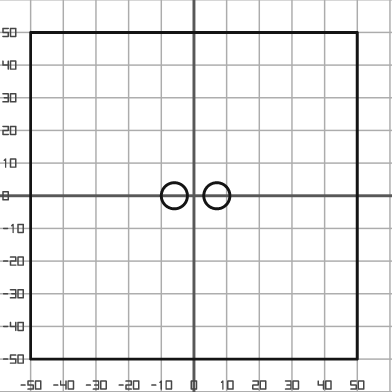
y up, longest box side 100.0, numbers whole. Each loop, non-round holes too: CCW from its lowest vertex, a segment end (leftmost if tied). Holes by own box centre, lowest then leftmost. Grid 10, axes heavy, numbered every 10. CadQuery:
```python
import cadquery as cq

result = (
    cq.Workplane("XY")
    .moveTo(-50.0, -50.0)
    .lineTo(50.0, -50.0)
    .lineTo(50.0, 50.0)
    .lineTo(-50.0, 50.0)
    .close()
    .moveTo(-6.0, 0.0)
    .circle(4.0)
    .moveTo(7.0, 0.0)
    .circle(4.0)
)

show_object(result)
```